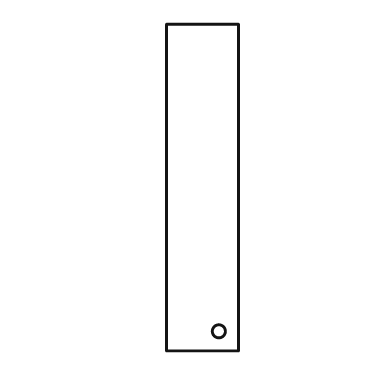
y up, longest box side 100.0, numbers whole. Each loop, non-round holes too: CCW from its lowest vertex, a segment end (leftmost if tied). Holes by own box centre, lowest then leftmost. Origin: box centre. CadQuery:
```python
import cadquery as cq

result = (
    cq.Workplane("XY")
    .moveTo(-11.0, -50.0)
    .lineTo(11.0, -50.0)
    .lineTo(11.0, 50.0)
    .lineTo(-11.0, 50.0)
    .close()
    .moveTo(5.0, -44.0)
    .circle(2.0)
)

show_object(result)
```